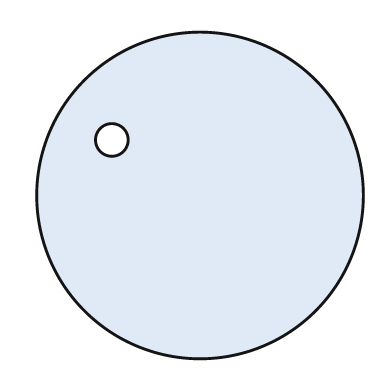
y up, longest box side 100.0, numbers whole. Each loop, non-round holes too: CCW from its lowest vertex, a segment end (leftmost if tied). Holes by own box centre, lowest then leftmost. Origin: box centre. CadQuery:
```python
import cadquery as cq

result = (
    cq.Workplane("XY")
    .moveTo(0.0, 0.0)
    .circle(50.0)
    .moveTo(-27.0, 17.0)
    .circle(5.0)
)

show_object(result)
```